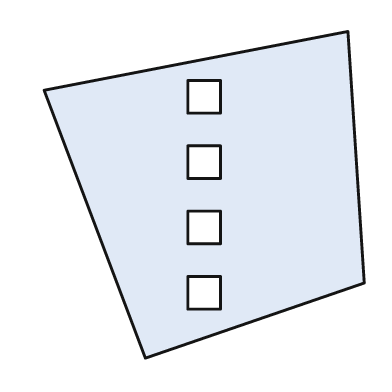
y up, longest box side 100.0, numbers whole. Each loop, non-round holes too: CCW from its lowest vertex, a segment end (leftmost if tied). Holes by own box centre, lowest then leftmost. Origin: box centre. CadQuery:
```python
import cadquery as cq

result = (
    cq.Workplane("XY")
    .moveTo(-18.0, -50.0)
    .lineTo(49.0, -27.0)
    .lineTo(44.0, 50.0)
    .lineTo(-49.0, 32.0)
    .close()
    .moveTo(-5.0, -35.0)
    .lineTo(5.0, -35.0)
    .lineTo(5.0, -25.0)
    .lineTo(-5.0, -25.0)
    .close()
    .moveTo(-5.0, -15.0)
    .lineTo(5.0, -15.0)
    .lineTo(5.0, -5.0)
    .lineTo(-5.0, -5.0)
    .close()
    .moveTo(-5.0, 5.0)
    .lineTo(5.0, 5.0)
    .lineTo(5.0, 15.0)
    .lineTo(-5.0, 15.0)
    .close()
    .moveTo(-5.0, 25.0)
    .lineTo(5.0, 25.0)
    .lineTo(5.0, 35.0)
    .lineTo(-5.0, 35.0)
    .close()
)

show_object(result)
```